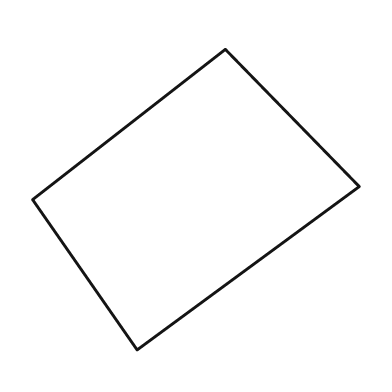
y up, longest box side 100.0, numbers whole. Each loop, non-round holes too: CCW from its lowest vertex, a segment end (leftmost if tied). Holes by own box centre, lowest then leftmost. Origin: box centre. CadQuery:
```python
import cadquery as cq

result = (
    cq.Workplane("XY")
    .moveTo(-18.0, -46.0)
    .lineTo(50.0, 4.0)
    .lineTo(9.0, 46.0)
    .lineTo(-50.0, 0.0)
    .close()
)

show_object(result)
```